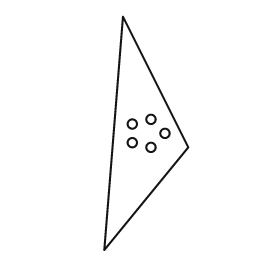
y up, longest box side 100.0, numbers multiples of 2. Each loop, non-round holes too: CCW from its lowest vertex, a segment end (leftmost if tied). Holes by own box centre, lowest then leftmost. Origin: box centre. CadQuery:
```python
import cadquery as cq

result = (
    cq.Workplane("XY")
    .moveTo(-18.0, -50.0)
    .lineTo(18.0, -6.0)
    .lineTo(-10.0, 50.0)
    .close()
    .moveTo(2.0, -6.0)
    .circle(2.0)
    .moveTo(-6.0, -4.0)
    .circle(2.0)
    .moveTo(8.0, 0.0)
    .circle(2.0)
    .moveTo(-6.0, 4.0)
    .circle(2.0)
    .moveTo(2.0, 6.0)
    .circle(2.0)
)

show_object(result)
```